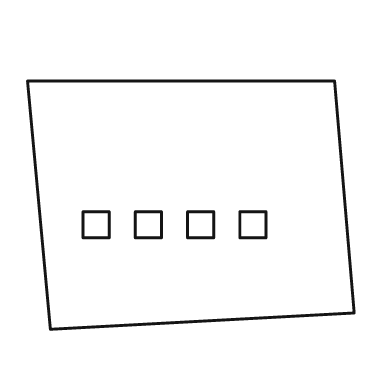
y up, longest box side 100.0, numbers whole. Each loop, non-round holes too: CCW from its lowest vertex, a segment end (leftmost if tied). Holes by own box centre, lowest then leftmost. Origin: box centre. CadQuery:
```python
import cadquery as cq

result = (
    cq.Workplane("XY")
    .moveTo(-43.0, -38.0)
    .lineTo(50.0, -33.0)
    .lineTo(44.0, 38.0)
    .lineTo(-50.0, 38.0)
    .close()
    .moveTo(-33.0, -10.0)
    .lineTo(-25.0, -10.0)
    .lineTo(-25.0, -2.0)
    .lineTo(-33.0, -2.0)
    .close()
    .moveTo(-17.0, -10.0)
    .lineTo(-9.0, -10.0)
    .lineTo(-9.0, -2.0)
    .lineTo(-17.0, -2.0)
    .close()
    .moveTo(-1.0, -10.0)
    .lineTo(7.0, -10.0)
    .lineTo(7.0, -2.0)
    .lineTo(-1.0, -2.0)
    .close()
    .moveTo(15.0, -10.0)
    .lineTo(23.0, -10.0)
    .lineTo(23.0, -2.0)
    .lineTo(15.0, -2.0)
    .close()
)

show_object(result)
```